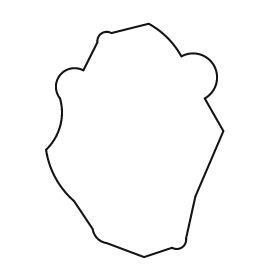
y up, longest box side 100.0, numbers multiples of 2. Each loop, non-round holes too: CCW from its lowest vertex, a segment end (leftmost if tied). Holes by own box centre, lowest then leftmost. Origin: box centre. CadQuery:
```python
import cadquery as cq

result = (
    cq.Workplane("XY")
    .moveTo(4.0, -50.0)
    .lineTo(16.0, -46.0)
    .threePointArc((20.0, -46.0), (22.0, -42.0))
    .lineTo(26.0, -24.0)
    .lineTo(38.0, 4.0)
    .lineTo(30.0, 18.0)
    .threePointArc((34.0, 32.0), (20.0, 36.0))
    .threePointArc((14.0, 44.0), (6.0, 50.0))
    .lineTo(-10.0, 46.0)
    .threePointArc((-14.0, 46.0), (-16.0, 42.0))
    .lineTo(-22.0, 30.0)
    .threePointArc((-32.0, 28.0), (-32.0, 18.0))
    .threePointArc((-32.0, 6.0), (-38.0, -4.0))
    .threePointArc((-34.0, -16.0), (-26.0, -26.0))
    .lineTo(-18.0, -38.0)
    .threePointArc((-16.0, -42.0), (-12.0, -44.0))
    .close()
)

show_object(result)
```